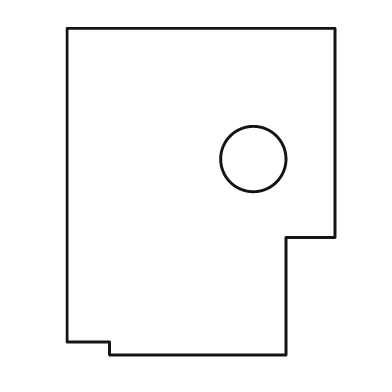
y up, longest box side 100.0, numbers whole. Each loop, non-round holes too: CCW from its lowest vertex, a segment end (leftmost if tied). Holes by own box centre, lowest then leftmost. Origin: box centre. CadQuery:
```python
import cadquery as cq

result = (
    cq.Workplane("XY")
    .moveTo(-28.0, -50.0)
    .lineTo(26.0, -50.0)
    .lineTo(26.0, -14.0)
    .lineTo(41.0, -14.0)
    .lineTo(41.0, 50.0)
    .lineTo(-41.0, 50.0)
    .lineTo(-41.0, -46.0)
    .lineTo(-28.0, -46.0)
    .close()
    .moveTo(16.0, 10.0)
    .circle(10.0)
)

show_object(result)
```